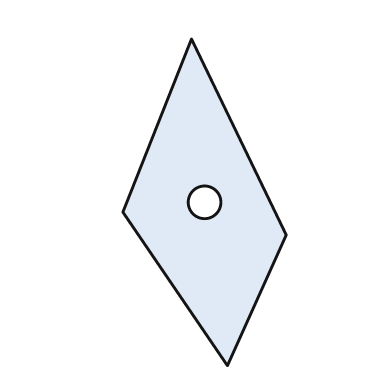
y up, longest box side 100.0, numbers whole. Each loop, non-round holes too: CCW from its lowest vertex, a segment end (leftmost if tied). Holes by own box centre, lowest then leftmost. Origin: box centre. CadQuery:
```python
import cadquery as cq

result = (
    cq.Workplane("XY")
    .moveTo(7.0, -50.0)
    .lineTo(25.0, -10.0)
    .lineTo(-4.0, 50.0)
    .lineTo(-25.0, -3.0)
    .close()
    .moveTo(0.0, 0.0)
    .circle(5.0)
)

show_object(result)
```